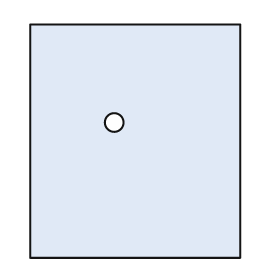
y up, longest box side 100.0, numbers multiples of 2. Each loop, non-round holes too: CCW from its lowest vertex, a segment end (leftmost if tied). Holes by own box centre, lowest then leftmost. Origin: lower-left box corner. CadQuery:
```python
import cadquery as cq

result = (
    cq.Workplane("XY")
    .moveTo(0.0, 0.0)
    .lineTo(90.0, 0.0)
    .lineTo(90.0, 100.0)
    .lineTo(0.0, 100.0)
    .close()
    .moveTo(36.0, 58.0)
    .circle(4.0)
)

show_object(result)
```